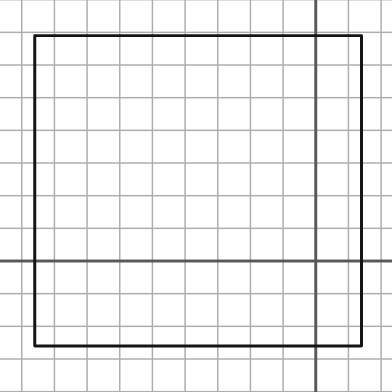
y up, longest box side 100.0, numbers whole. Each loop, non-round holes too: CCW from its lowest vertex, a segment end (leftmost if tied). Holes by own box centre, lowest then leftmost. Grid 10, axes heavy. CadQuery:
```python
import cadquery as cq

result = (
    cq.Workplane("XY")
    .moveTo(-86.0, -26.0)
    .lineTo(14.0, -26.0)
    .lineTo(14.0, 69.0)
    .lineTo(-86.0, 69.0)
    .close()
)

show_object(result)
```